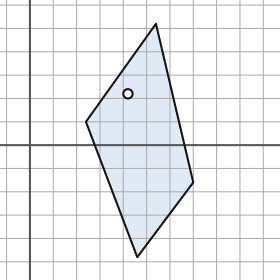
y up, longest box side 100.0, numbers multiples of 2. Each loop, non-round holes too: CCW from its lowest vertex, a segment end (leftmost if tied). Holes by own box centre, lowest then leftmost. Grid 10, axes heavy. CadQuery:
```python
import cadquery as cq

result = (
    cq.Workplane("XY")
    .moveTo(46.0, -48.0)
    .lineTo(70.0, -16.0)
    .lineTo(54.0, 52.0)
    .lineTo(24.0, 10.0)
    .close()
    .moveTo(42.0, 22.0)
    .circle(2.0)
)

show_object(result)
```